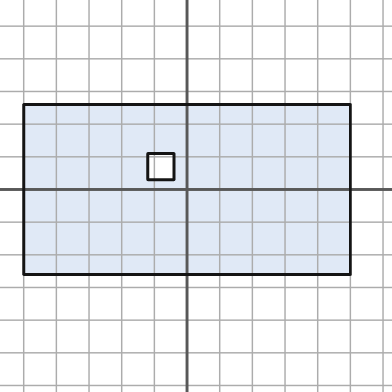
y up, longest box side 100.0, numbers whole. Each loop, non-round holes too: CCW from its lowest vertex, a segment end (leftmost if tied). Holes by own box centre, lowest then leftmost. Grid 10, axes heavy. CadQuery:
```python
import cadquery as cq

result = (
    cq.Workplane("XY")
    .moveTo(-50.0, -26.0)
    .lineTo(50.0, -26.0)
    .lineTo(50.0, 26.0)
    .lineTo(-50.0, 26.0)
    .close()
    .moveTo(-12.0, 3.0)
    .lineTo(-4.0, 3.0)
    .lineTo(-4.0, 11.0)
    .lineTo(-12.0, 11.0)
    .close()
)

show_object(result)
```